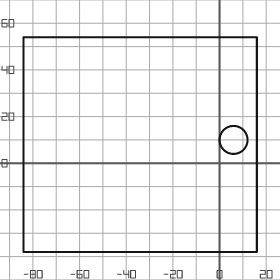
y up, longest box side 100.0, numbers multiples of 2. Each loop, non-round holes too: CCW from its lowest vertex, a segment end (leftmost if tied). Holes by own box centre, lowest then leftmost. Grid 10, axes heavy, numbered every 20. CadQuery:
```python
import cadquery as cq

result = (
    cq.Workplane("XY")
    .moveTo(-84.0, -38.0)
    .lineTo(16.0, -38.0)
    .lineTo(16.0, 54.0)
    .lineTo(-84.0, 54.0)
    .close()
    .moveTo(6.0, 10.0)
    .circle(6.0)
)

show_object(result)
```